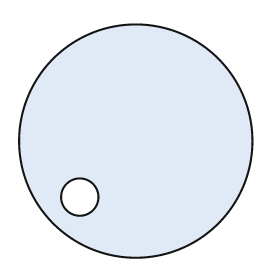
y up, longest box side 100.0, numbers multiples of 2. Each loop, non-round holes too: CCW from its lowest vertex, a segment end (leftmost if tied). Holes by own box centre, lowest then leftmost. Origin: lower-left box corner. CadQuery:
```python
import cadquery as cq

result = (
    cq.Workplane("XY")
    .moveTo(50.0, 50.0)
    .circle(50.0)
    .moveTo(26.0, 26.0)
    .circle(8.0)
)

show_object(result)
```